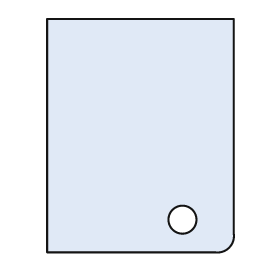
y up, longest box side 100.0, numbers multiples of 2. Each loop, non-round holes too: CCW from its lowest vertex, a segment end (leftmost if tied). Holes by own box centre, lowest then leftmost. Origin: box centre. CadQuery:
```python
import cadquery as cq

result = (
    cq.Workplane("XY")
    .moveTo(-40.0, -50.0)
    .lineTo(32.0, -50.0)
    .threePointArc((38.0, -48.0), (40.0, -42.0))
    .lineTo(40.0, 50.0)
    .lineTo(-40.0, 50.0)
    .close()
    .moveTo(18.0, -36.0)
    .circle(6.0)
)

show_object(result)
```